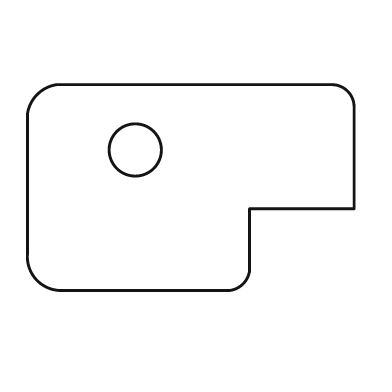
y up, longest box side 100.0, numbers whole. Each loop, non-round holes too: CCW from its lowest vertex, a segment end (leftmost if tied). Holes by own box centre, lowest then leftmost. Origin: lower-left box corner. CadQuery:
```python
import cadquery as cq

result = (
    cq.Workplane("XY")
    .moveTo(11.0, 0.0)
    .lineTo(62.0, 0.0)
    .threePointArc((66.0, 2.0), (68.0, 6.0))
    .lineTo(68.0, 25.0)
    .lineTo(100.0, 25.0)
    .lineTo(100.0, 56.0)
    .threePointArc((98.0, 61.0), (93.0, 63.0))
    .lineTo(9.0, 63.0)
    .threePointArc((3.0, 60.0), (0.0, 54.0))
    .lineTo(0.0, 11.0)
    .threePointArc((3.0, 3.0), (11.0, 0.0))
    .close()
    .moveTo(33.0, 43.0)
    .circle(8.0)
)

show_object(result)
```